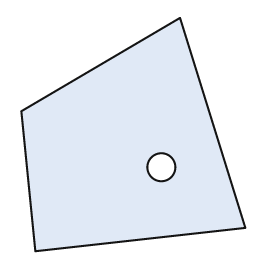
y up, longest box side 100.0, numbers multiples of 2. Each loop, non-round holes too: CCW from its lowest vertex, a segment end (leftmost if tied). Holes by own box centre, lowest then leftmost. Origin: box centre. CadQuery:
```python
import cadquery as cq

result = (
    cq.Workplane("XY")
    .moveTo(-42.0, -50.0)
    .lineTo(48.0, -40.0)
    .lineTo(20.0, 50.0)
    .lineTo(-48.0, 10.0)
    .close()
    .moveTo(12.0, -14.0)
    .circle(6.0)
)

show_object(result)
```